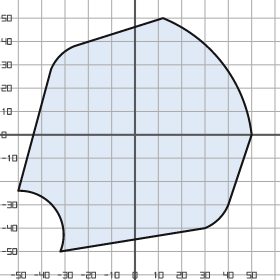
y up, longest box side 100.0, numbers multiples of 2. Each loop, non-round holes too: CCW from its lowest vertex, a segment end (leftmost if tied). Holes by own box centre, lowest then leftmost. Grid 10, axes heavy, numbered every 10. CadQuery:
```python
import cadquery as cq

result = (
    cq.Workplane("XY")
    .moveTo(-32.0, -50.0)
    .lineTo(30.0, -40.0)
    .threePointArc((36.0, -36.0), (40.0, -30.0))
    .lineTo(50.0, 0.0)
    .threePointArc((38.0, 30.0), (12.0, 50.0))
    .lineTo(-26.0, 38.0)
    .threePointArc((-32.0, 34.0), (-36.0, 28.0))
    .lineTo(-50.0, -24.0)
    .threePointArc((-34.0, -32.0), (-32.0, -50.0))
    .close()
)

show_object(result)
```